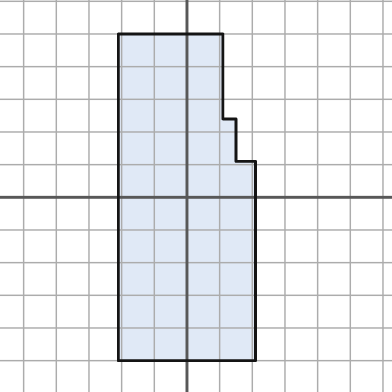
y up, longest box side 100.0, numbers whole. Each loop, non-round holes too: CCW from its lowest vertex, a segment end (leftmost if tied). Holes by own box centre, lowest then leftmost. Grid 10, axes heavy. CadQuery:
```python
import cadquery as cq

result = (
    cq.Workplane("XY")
    .moveTo(-21.0, -50.0)
    .lineTo(21.0, -50.0)
    .lineTo(21.0, 11.0)
    .lineTo(15.0, 11.0)
    .lineTo(15.0, 24.0)
    .lineTo(11.0, 24.0)
    .lineTo(11.0, 50.0)
    .lineTo(-21.0, 50.0)
    .close()
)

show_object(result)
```